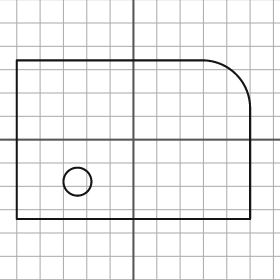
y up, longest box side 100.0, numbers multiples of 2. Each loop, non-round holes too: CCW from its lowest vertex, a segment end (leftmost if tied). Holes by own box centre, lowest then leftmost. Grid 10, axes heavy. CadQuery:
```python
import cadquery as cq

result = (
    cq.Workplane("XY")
    .moveTo(-50.0, -34.0)
    .lineTo(50.0, -34.0)
    .lineTo(50.0, 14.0)
    .threePointArc((44.0, 28.0), (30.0, 34.0))
    .lineTo(-50.0, 34.0)
    .close()
    .moveTo(-24.0, -18.0)
    .circle(6.0)
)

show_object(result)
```